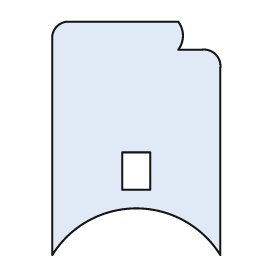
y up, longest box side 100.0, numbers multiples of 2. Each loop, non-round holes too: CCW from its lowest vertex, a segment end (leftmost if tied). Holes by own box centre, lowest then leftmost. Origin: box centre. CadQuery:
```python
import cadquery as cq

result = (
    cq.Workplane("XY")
    .moveTo(-36.0, -50.0)
    .threePointArc((0.0, -30.0), (36.0, -50.0))
    .lineTo(36.0, 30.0)
    .threePointArc((34.0, 36.0), (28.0, 38.0))
    .lineTo(18.0, 38.0)
    .threePointArc((20.0, 44.0), (18.0, 50.0))
    .lineTo(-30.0, 50.0)
    .threePointArc((-34.0, 48.0), (-36.0, 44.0))
    .close()
    .moveTo(-6.0, -22.0)
    .lineTo(6.0, -22.0)
    .lineTo(6.0, -6.0)
    .lineTo(-6.0, -6.0)
    .close()
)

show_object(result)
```